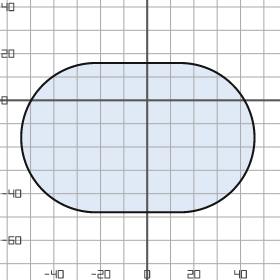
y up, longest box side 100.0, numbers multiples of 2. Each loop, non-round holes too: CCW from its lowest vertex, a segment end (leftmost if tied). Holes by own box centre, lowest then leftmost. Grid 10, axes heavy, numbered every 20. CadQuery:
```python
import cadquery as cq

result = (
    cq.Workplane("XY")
    .moveTo(-22.0, -48.0)
    .lineTo(14.0, -48.0)
    .threePointArc((46.0, -16.0), (14.0, 16.0))
    .lineTo(-22.0, 16.0)
    .threePointArc((-54.0, -16.0), (-22.0, -48.0))
    .close()
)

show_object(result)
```